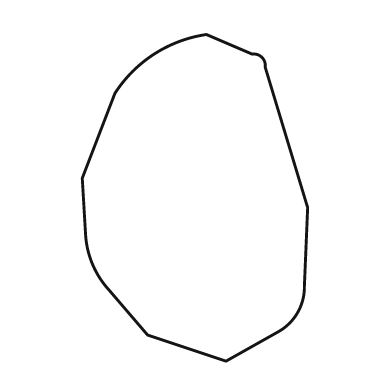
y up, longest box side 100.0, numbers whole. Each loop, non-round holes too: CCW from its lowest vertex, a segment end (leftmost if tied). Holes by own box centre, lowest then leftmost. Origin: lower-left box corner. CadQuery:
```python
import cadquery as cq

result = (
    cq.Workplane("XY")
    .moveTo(44.0, 0.0)
    .lineTo(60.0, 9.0)
    .threePointArc((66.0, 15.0), (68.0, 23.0))
    .lineTo(69.0, 47.0)
    .lineTo(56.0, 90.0)
    .threePointArc((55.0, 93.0), (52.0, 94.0))
    .lineTo(38.0, 100.0)
    .threePointArc((22.0, 94.0), (10.0, 82.0))
    .lineTo(0.0, 56.0)
    .lineTo(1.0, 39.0)
    .threePointArc((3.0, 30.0), (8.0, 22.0))
    .lineTo(20.0, 8.0)
    .close()
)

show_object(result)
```